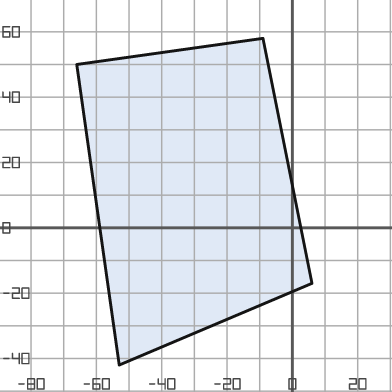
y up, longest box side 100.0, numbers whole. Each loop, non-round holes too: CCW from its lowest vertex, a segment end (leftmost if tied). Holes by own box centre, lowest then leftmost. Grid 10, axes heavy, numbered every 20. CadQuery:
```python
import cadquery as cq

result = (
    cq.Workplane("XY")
    .moveTo(-53.0, -42.0)
    .lineTo(6.0, -17.0)
    .lineTo(-9.0, 58.0)
    .lineTo(-66.0, 50.0)
    .close()
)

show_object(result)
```